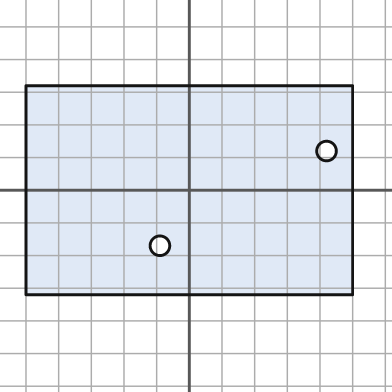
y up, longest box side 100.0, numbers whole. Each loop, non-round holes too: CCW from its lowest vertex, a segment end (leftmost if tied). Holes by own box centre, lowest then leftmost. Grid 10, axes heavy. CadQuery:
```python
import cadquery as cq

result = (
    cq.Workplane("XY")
    .moveTo(-50.0, -32.0)
    .lineTo(50.0, -32.0)
    .lineTo(50.0, 32.0)
    .lineTo(-50.0, 32.0)
    .close()
    .moveTo(-9.0, -17.0)
    .circle(3.0)
    .moveTo(42.0, 12.0)
    .circle(3.0)
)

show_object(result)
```